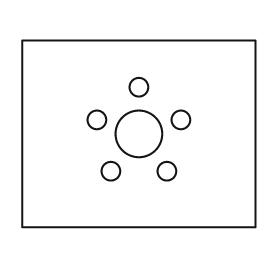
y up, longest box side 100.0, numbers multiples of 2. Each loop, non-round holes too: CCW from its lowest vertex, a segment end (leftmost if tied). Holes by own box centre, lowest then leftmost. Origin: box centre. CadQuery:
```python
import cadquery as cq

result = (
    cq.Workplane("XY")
    .moveTo(-50.0, -40.0)
    .lineTo(50.0, -40.0)
    .lineTo(50.0, 40.0)
    .lineTo(-50.0, 40.0)
    .close()
    .moveTo(-12.0, -16.0)
    .circle(4.0)
    .moveTo(12.0, -16.0)
    .circle(4.0)
    .moveTo(0.0, 0.0)
    .circle(10.0)
    .moveTo(-18.0, 6.0)
    .circle(4.0)
    .moveTo(18.0, 6.0)
    .circle(4.0)
    .moveTo(0.0, 20.0)
    .circle(4.0)
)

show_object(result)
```